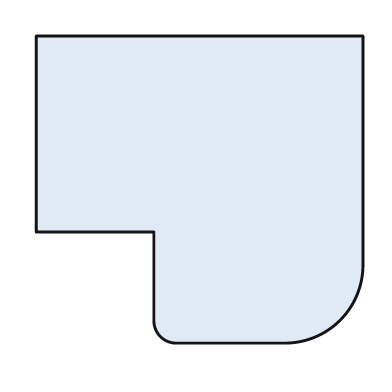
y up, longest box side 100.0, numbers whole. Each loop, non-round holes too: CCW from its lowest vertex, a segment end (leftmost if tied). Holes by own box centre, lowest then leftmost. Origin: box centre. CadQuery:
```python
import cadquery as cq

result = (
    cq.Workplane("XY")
    .moveTo(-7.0, -47.0)
    .lineTo(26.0, -47.0)
    .threePointArc((43.0, -40.0), (50.0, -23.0))
    .lineTo(50.0, 47.0)
    .lineTo(-50.0, 47.0)
    .lineTo(-50.0, -13.0)
    .lineTo(-14.0, -13.0)
    .lineTo(-14.0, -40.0)
    .threePointArc((-12.0, -45.0), (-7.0, -47.0))
    .close()
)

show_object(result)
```